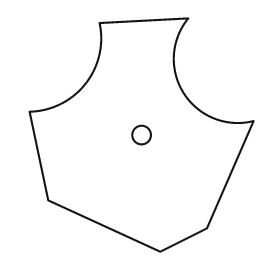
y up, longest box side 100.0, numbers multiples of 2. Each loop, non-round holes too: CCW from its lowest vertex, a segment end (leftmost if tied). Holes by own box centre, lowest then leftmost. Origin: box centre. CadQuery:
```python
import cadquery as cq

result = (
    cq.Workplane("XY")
    .moveTo(8.0, -50.0)
    .lineTo(28.0, -40.0)
    .lineTo(48.0, 6.0)
    .threePointArc((18.0, 18.0), (20.0, 50.0))
    .lineTo(-18.0, 48.0)
    .threePointArc((-24.0, 22.0), (-48.0, 10.0))
    .lineTo(-40.0, -28.0)
    .close()
    .moveTo(0.0, 0.0)
    .circle(4.0)
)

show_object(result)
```